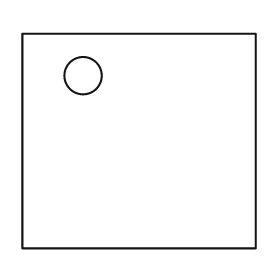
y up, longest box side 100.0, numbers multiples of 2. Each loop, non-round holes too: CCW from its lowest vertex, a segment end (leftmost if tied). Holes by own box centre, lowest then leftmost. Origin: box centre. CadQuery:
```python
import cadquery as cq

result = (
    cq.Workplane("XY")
    .moveTo(-50.0, -46.0)
    .lineTo(50.0, -46.0)
    .lineTo(50.0, 46.0)
    .lineTo(-50.0, 46.0)
    .close()
    .moveTo(-24.0, 28.0)
    .circle(8.0)
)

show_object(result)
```